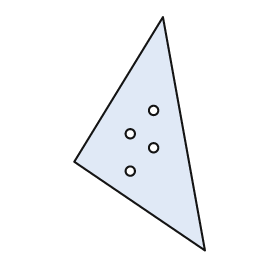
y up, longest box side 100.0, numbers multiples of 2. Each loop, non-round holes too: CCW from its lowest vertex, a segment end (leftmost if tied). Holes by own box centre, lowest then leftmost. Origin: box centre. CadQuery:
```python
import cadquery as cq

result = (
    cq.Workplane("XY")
    .moveTo(28.0, -50.0)
    .lineTo(10.0, 50.0)
    .lineTo(-28.0, -12.0)
    .close()
    .moveTo(-4.0, -16.0)
    .circle(2.0)
    .moveTo(6.0, -6.0)
    .circle(2.0)
    .moveTo(-4.0, 0.0)
    .circle(2.0)
    .moveTo(6.0, 10.0)
    .circle(2.0)
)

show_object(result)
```